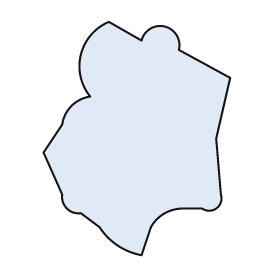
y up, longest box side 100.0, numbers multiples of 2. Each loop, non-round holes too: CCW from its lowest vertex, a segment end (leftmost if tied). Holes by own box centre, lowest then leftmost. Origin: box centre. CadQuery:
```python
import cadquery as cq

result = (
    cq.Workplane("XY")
    .moveTo(2.0, -50.0)
    .lineTo(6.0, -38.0)
    .threePointArc((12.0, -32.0), (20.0, -30.0))
    .lineTo(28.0, -30.0)
    .threePointArc((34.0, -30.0), (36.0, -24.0))
    .lineTo(34.0, 0.0)
    .lineTo(40.0, 26.0)
    .lineTo(18.0, 38.0)
    .threePointArc((12.0, 48.0), (2.0, 42.0))
    .lineTo(-12.0, 50.0)
    .threePointArc((-24.0, 36.0), (-20.0, 18.0))
    .threePointArc((-28.0, 14.0), (-32.0, 6.0))
    .lineTo(-40.0, -6.0)
    .lineTo(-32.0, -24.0)
    .threePointArc((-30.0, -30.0), (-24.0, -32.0))
    .lineTo(-16.0, -38.0)
    .threePointArc((-8.0, -46.0), (2.0, -50.0))
    .close()
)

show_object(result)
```